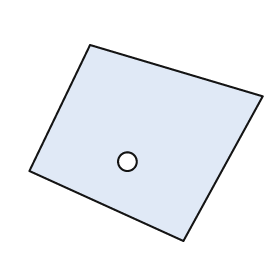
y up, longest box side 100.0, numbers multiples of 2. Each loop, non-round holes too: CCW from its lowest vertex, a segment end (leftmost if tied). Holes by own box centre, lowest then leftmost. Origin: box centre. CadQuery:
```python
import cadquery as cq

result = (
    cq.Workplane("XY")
    .moveTo(16.0, -42.0)
    .lineTo(50.0, 20.0)
    .lineTo(-24.0, 42.0)
    .lineTo(-50.0, -12.0)
    .close()
    .moveTo(-8.0, -8.0)
    .circle(4.0)
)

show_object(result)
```